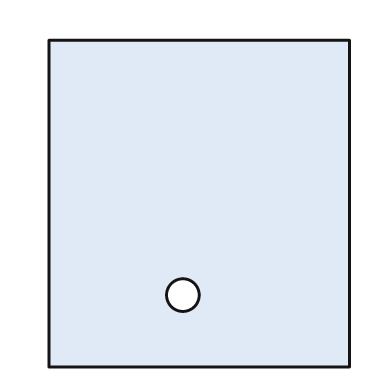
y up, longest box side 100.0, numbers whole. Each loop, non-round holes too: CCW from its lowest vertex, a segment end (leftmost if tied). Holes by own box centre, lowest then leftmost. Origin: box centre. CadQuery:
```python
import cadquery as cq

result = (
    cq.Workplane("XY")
    .moveTo(-46.0, -50.0)
    .lineTo(46.0, -50.0)
    .lineTo(46.0, 50.0)
    .lineTo(-46.0, 50.0)
    .close()
    .moveTo(-5.0, -28.0)
    .circle(5.0)
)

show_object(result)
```